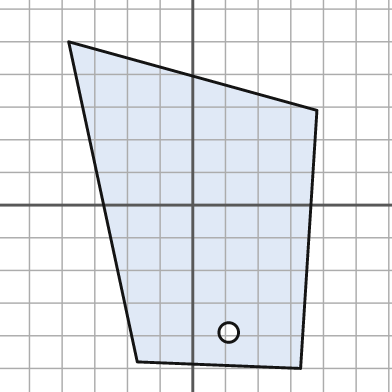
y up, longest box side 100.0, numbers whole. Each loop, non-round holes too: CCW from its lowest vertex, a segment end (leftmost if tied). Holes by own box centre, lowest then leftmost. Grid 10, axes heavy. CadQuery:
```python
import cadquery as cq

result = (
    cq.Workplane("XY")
    .moveTo(33.0, -50.0)
    .lineTo(38.0, 29.0)
    .lineTo(-38.0, 50.0)
    .lineTo(-17.0, -48.0)
    .close()
    .moveTo(11.0, -39.0)
    .circle(3.0)
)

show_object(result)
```